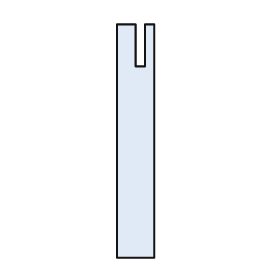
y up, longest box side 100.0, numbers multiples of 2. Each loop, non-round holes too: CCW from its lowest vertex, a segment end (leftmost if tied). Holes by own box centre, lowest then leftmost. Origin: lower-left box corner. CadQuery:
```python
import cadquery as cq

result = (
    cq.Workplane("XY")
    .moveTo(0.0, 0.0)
    .lineTo(16.0, 0.0)
    .lineTo(16.0, 100.0)
    .lineTo(12.0, 100.0)
    .lineTo(12.0, 82.0)
    .lineTo(8.0, 82.0)
    .lineTo(8.0, 100.0)
    .lineTo(0.0, 100.0)
    .close()
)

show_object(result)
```